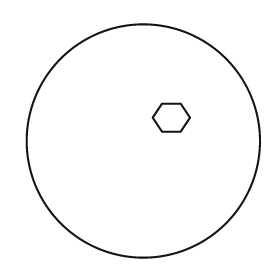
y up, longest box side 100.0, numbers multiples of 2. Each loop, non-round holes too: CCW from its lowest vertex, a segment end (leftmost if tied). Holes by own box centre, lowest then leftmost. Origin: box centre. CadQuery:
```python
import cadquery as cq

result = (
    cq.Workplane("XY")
    .moveTo(0.0, 0.0)
    .circle(50.0)
    .moveTo(8.0, 4.0)
    .lineTo(16.0, 4.0)
    .lineTo(20.0, 10.0)
    .lineTo(16.0, 16.0)
    .lineTo(8.0, 16.0)
    .lineTo(4.0, 10.0)
    .close()
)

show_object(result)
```